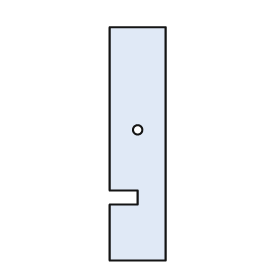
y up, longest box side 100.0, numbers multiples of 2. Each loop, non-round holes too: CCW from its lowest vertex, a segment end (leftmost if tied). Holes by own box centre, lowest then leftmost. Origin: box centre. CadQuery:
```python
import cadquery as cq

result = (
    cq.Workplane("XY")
    .moveTo(-12.0, -50.0)
    .lineTo(12.0, -50.0)
    .lineTo(12.0, 50.0)
    .lineTo(-12.0, 50.0)
    .lineTo(-12.0, -20.0)
    .lineTo(0.0, -20.0)
    .lineTo(0.0, -26.0)
    .lineTo(-12.0, -26.0)
    .close()
    .moveTo(0.0, 6.0)
    .circle(2.0)
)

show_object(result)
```